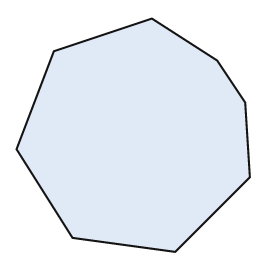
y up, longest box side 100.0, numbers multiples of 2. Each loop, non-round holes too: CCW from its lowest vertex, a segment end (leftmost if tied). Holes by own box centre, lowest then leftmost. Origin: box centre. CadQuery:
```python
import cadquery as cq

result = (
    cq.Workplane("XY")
    .moveTo(18.0, -50.0)
    .lineTo(50.0, -18.0)
    .lineTo(48.0, 14.0)
    .lineTo(36.0, 32.0)
    .lineTo(8.0, 50.0)
    .lineTo(-34.0, 36.0)
    .lineTo(-50.0, -6.0)
    .lineTo(-26.0, -44.0)
    .close()
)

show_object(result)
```